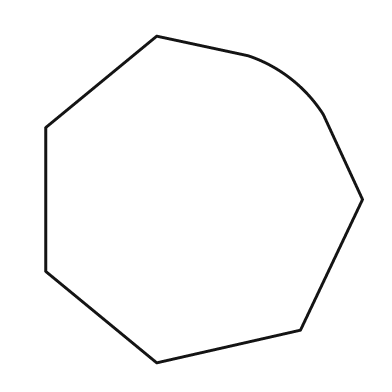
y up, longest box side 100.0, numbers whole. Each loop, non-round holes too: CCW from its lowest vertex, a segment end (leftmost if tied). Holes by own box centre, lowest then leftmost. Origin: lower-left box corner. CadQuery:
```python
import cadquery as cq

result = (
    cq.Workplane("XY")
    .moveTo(34.0, 0.0)
    .lineTo(78.0, 10.0)
    .lineTo(97.0, 50.0)
    .lineTo(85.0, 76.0)
    .threePointArc((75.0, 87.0), (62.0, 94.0))
    .lineTo(34.0, 100.0)
    .lineTo(0.0, 72.0)
    .lineTo(0.0, 28.0)
    .close()
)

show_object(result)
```